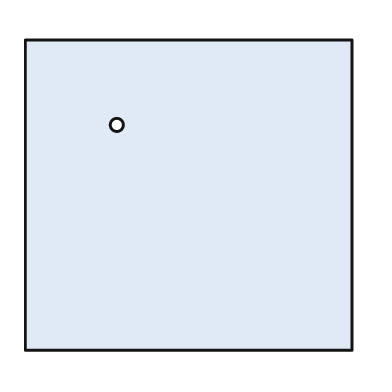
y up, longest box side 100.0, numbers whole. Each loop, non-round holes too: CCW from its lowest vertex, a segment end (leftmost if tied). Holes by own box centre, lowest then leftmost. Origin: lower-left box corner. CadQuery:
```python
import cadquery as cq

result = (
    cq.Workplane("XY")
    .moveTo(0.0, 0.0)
    .lineTo(100.0, 0.0)
    .lineTo(100.0, 95.0)
    .lineTo(0.0, 95.0)
    .close()
    .moveTo(28.0, 69.0)
    .circle(2.0)
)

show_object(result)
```